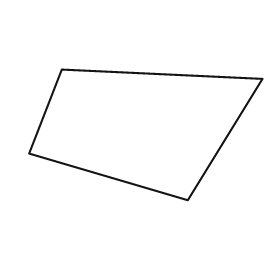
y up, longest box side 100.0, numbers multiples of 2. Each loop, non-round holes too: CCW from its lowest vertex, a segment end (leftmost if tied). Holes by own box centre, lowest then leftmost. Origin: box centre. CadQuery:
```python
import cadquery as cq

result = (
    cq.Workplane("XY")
    .moveTo(18.0, -28.0)
    .lineTo(50.0, 24.0)
    .lineTo(-36.0, 28.0)
    .lineTo(-50.0, -8.0)
    .close()
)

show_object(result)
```